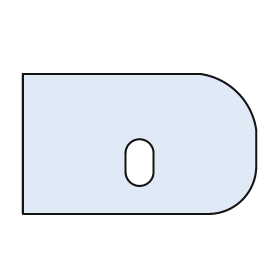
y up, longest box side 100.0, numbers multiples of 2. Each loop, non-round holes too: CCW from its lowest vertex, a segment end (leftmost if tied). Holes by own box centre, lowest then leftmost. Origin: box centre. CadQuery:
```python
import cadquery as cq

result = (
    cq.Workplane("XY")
    .moveTo(-50.0, -30.0)
    .lineTo(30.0, -30.0)
    .threePointArc((44.0, -24.0), (50.0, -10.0))
    .lineTo(50.0, 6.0)
    .threePointArc((42.0, 22.0), (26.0, 30.0))
    .lineTo(-50.0, 30.0)
    .close()
    .moveTo(-6.0, -12.0)
    .threePointArc((0.0, -18.0), (6.0, -12.0))
    .lineTo(6.0, -4.0)
    .threePointArc((0.0, 2.0), (-6.0, -4.0))
    .close()
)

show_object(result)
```